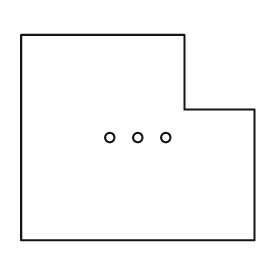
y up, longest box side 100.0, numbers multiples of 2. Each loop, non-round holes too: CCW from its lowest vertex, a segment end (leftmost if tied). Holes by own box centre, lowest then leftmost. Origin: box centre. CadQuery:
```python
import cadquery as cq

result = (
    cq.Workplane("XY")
    .moveTo(-50.0, -44.0)
    .lineTo(50.0, -44.0)
    .lineTo(50.0, 12.0)
    .lineTo(20.0, 12.0)
    .lineTo(20.0, 44.0)
    .lineTo(-50.0, 44.0)
    .close()
    .moveTo(-12.0, 0.0)
    .circle(2.0)
    .moveTo(0.0, 0.0)
    .circle(2.0)
    .moveTo(12.0, 0.0)
    .circle(2.0)
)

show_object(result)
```